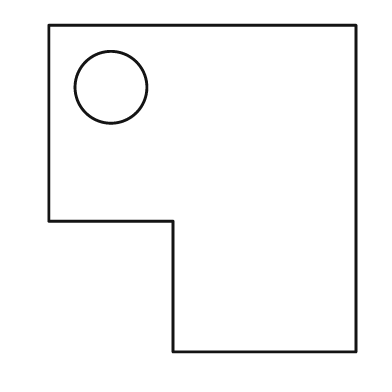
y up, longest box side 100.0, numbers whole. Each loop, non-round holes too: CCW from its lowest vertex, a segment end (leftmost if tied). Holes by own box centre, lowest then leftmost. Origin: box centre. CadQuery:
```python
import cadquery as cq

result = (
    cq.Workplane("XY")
    .moveTo(-9.0, -50.0)
    .lineTo(47.0, -50.0)
    .lineTo(47.0, 50.0)
    .lineTo(-47.0, 50.0)
    .lineTo(-47.0, -10.0)
    .lineTo(-9.0, -10.0)
    .close()
    .moveTo(-28.0, 31.0)
    .circle(11.0)
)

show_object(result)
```